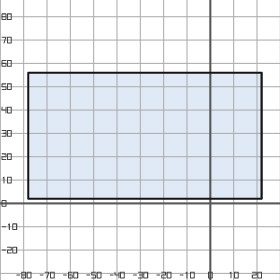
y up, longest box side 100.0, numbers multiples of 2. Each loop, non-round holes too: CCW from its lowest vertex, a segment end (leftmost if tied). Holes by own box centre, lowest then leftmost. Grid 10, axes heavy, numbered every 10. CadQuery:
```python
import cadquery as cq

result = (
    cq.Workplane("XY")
    .moveTo(-78.0, 2.0)
    .lineTo(22.0, 2.0)
    .lineTo(22.0, 56.0)
    .lineTo(-78.0, 56.0)
    .close()
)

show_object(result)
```